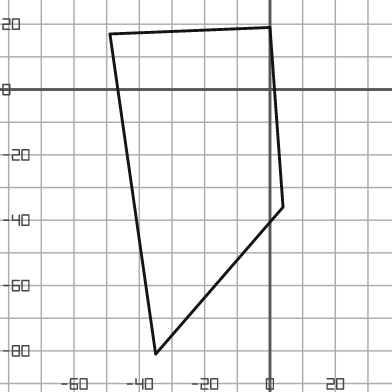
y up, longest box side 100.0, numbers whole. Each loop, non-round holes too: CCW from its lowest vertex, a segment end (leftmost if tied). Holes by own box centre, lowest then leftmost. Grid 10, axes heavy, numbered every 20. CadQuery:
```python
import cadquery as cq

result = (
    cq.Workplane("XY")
    .moveTo(-35.0, -81.0)
    .lineTo(4.0, -36.0)
    .lineTo(0.0, 19.0)
    .lineTo(-49.0, 17.0)
    .close()
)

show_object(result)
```